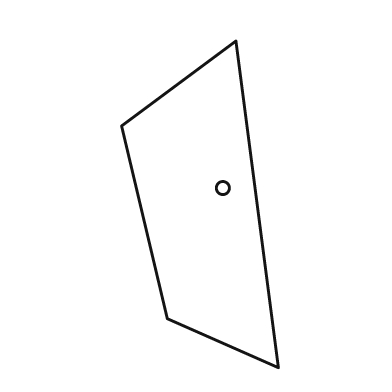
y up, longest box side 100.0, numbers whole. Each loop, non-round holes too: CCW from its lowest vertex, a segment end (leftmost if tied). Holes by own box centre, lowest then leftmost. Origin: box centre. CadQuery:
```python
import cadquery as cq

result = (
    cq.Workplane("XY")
    .moveTo(24.0, -50.0)
    .lineTo(11.0, 50.0)
    .lineTo(-24.0, 24.0)
    .lineTo(-10.0, -35.0)
    .close()
    .moveTo(7.0, 5.0)
    .circle(2.0)
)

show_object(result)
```